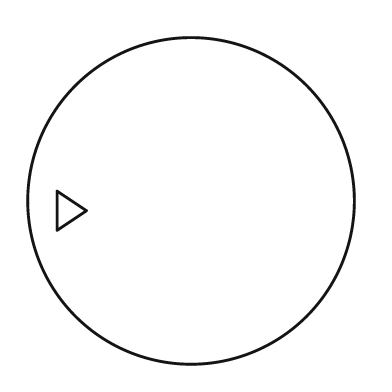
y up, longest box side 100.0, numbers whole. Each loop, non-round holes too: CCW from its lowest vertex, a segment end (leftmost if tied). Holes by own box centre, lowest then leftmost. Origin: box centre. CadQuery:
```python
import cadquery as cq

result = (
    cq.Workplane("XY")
    .moveTo(0.0, 0.0)
    .circle(50.0)
    .moveTo(-41.0, -9.0)
    .lineTo(-32.0, -3.0)
    .lineTo(-41.0, 3.0)
    .close()
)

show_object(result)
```